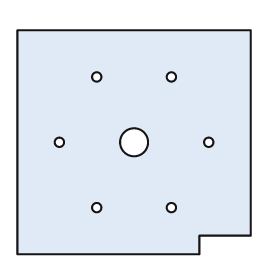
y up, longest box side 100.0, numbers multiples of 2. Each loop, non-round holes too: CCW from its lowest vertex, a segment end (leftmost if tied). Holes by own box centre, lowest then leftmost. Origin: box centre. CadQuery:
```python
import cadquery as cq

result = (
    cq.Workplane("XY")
    .moveTo(-50.0, -48.0)
    .lineTo(28.0, -48.0)
    .lineTo(28.0, -40.0)
    .lineTo(50.0, -40.0)
    .lineTo(50.0, 48.0)
    .lineTo(-50.0, 48.0)
    .close()
    .moveTo(-16.0, -28.0)
    .circle(2.0)
    .moveTo(16.0, -28.0)
    .circle(2.0)
    .moveTo(-32.0, 0.0)
    .circle(2.0)
    .moveTo(0.0, 0.0)
    .circle(6.0)
    .moveTo(32.0, 0.0)
    .circle(2.0)
    .moveTo(-16.0, 28.0)
    .circle(2.0)
    .moveTo(16.0, 28.0)
    .circle(2.0)
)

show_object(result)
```